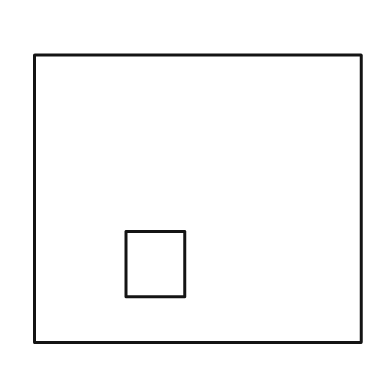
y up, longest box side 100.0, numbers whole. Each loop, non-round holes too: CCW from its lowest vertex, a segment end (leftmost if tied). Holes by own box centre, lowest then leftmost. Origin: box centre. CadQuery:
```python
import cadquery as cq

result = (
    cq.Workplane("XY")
    .moveTo(-50.0, -44.0)
    .lineTo(50.0, -44.0)
    .lineTo(50.0, 44.0)
    .lineTo(-50.0, 44.0)
    .close()
    .moveTo(-22.0, -30.0)
    .lineTo(-4.0, -30.0)
    .lineTo(-4.0, -10.0)
    .lineTo(-22.0, -10.0)
    .close()
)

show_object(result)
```